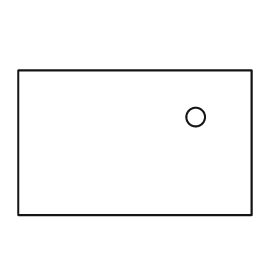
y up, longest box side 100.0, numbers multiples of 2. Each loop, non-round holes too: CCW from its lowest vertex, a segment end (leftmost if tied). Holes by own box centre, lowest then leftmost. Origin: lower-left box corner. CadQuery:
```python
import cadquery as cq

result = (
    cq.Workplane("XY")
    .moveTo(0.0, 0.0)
    .lineTo(100.0, 0.0)
    .lineTo(100.0, 62.0)
    .lineTo(0.0, 62.0)
    .close()
    .moveTo(76.0, 42.0)
    .circle(4.0)
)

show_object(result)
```